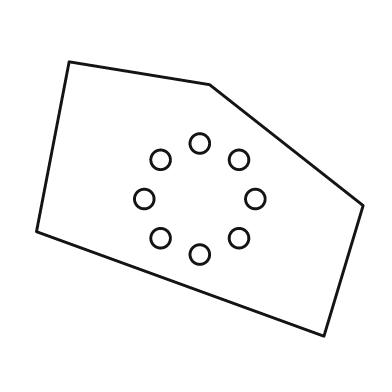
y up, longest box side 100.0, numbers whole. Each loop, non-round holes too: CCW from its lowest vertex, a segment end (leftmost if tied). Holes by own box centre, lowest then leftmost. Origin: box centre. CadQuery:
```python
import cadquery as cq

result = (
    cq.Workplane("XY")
    .moveTo(38.0, -42.0)
    .lineTo(50.0, -2.0)
    .lineTo(3.0, 35.0)
    .lineTo(-40.0, 42.0)
    .lineTo(-50.0, -10.0)
    .close()
    .moveTo(0.0, -17.0)
    .circle(3.0)
    .moveTo(-12.0, -12.0)
    .circle(3.0)
    .moveTo(12.0, -12.0)
    .circle(3.0)
    .moveTo(-17.0, 0.0)
    .circle(3.0)
    .moveTo(17.0, 0.0)
    .circle(3.0)
    .moveTo(-12.0, 12.0)
    .circle(3.0)
    .moveTo(12.0, 12.0)
    .circle(3.0)
    .moveTo(0.0, 17.0)
    .circle(3.0)
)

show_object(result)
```